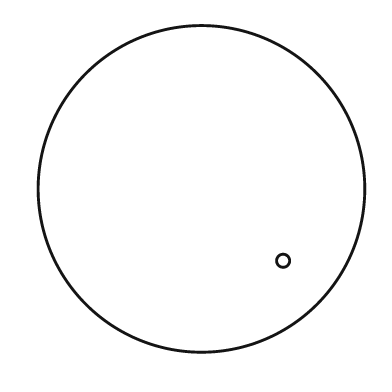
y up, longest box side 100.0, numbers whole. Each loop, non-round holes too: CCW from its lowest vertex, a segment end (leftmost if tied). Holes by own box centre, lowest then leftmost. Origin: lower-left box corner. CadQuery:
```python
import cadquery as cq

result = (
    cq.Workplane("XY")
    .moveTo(50.0, 50.0)
    .circle(50.0)
    .moveTo(75.0, 28.0)
    .circle(2.0)
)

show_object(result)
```